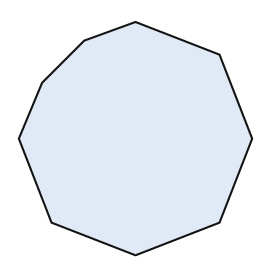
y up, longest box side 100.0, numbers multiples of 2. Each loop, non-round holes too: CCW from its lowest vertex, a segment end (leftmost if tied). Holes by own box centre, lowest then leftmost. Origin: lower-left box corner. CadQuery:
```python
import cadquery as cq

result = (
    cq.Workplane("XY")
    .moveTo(50.0, 0.0)
    .lineTo(86.0, 14.0)
    .lineTo(100.0, 50.0)
    .lineTo(86.0, 86.0)
    .lineTo(50.0, 100.0)
    .lineTo(28.0, 92.0)
    .lineTo(10.0, 74.0)
    .lineTo(0.0, 50.0)
    .lineTo(14.0, 14.0)
    .close()
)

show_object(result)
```